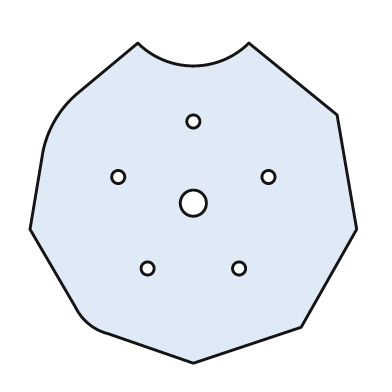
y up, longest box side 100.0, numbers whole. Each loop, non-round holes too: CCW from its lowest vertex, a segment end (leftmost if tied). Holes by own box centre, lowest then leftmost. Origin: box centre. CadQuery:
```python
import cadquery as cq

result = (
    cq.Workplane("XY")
    .moveTo(0.0, -49.0)
    .lineTo(33.0, -38.0)
    .lineTo(50.0, -8.0)
    .lineTo(44.0, 27.0)
    .lineTo(17.0, 49.0)
    .threePointArc((0.0, 42.0), (-17.0, 49.0))
    .lineTo(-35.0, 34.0)
    .threePointArc((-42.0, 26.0), (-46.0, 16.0))
    .lineTo(-50.0, -8.0)
    .lineTo(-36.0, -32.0)
    .threePointArc((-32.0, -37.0), (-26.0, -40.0))
    .close()
    .moveTo(-14.0, -20.0)
    .circle(2.0)
    .moveTo(14.0, -20.0)
    .circle(2.0)
    .moveTo(0.0, 0.0)
    .circle(4.0)
    .moveTo(-23.0, 8.0)
    .circle(2.0)
    .moveTo(23.0, 8.0)
    .circle(2.0)
    .moveTo(0.0, 25.0)
    .circle(2.0)
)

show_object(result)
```